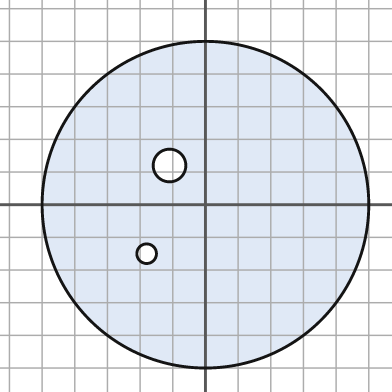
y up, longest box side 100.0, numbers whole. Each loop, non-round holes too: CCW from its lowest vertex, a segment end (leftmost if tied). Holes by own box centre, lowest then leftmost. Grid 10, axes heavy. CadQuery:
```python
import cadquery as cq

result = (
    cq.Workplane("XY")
    .moveTo(0.0, 0.0)
    .circle(50.0)
    .moveTo(-18.0, -15.0)
    .circle(3.0)
    .moveTo(-11.0, 12.0)
    .circle(5.0)
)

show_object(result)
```